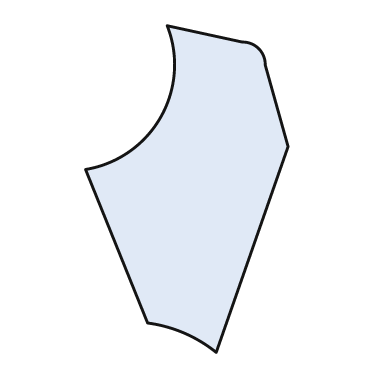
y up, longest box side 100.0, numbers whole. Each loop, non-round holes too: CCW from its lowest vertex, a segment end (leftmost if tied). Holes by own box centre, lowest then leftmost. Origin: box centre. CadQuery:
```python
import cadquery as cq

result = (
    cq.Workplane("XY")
    .moveTo(9.0, -50.0)
    .lineTo(31.0, 13.0)
    .lineTo(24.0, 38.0)
    .threePointArc((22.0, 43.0), (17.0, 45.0))
    .lineTo(-6.0, 50.0)
    .threePointArc((-8.0, 22.0), (-31.0, 6.0))
    .lineTo(-12.0, -41.0)
    .threePointArc((-1.0, -44.0), (9.0, -50.0))
    .close()
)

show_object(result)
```